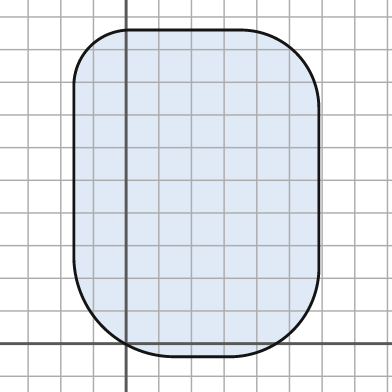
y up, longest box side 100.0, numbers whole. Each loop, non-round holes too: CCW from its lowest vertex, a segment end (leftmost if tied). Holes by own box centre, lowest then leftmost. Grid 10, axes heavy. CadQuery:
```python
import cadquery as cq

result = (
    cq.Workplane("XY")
    .moveTo(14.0, -4.0)
    .lineTo(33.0, -4.0)
    .threePointArc((51.0, 4.0), (59.0, 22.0))
    .lineTo(59.0, 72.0)
    .threePointArc((52.0, 89.0), (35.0, 96.0))
    .lineTo(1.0, 96.0)
    .threePointArc((-11.0, 91.0), (-16.0, 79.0))
    .lineTo(-16.0, 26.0)
    .threePointArc((-7.0, 5.0), (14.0, -4.0))
    .close()
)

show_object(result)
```